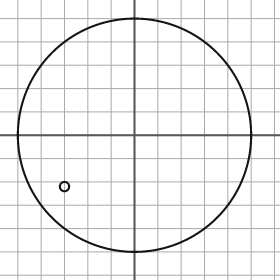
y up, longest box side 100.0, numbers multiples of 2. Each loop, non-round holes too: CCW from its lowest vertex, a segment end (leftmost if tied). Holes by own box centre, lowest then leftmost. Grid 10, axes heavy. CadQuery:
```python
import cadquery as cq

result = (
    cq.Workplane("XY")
    .moveTo(0.0, 0.0)
    .circle(50.0)
    .moveTo(-30.0, -22.0)
    .circle(2.0)
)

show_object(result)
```